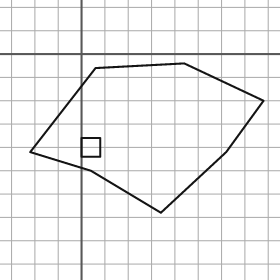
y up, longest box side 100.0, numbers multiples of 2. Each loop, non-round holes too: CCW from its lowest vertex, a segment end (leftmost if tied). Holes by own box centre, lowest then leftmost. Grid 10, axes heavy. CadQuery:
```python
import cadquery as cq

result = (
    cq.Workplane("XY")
    .moveTo(34.0, -68.0)
    .lineTo(62.0, -42.0)
    .lineTo(78.0, -20.0)
    .lineTo(44.0, -4.0)
    .lineTo(6.0, -6.0)
    .lineTo(-22.0, -42.0)
    .lineTo(4.0, -50.0)
    .close()
    .moveTo(0.0, -44.0)
    .lineTo(8.0, -44.0)
    .lineTo(8.0, -36.0)
    .lineTo(0.0, -36.0)
    .close()
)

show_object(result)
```